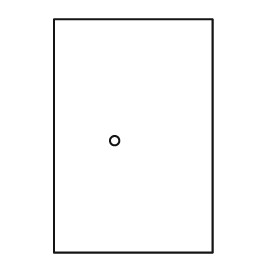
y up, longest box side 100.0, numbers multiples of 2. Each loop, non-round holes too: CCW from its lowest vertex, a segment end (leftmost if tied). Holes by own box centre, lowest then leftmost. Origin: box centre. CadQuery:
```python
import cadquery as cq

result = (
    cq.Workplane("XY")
    .moveTo(-34.0, -50.0)
    .lineTo(34.0, -50.0)
    .lineTo(34.0, 50.0)
    .lineTo(-34.0, 50.0)
    .close()
    .moveTo(-8.0, -2.0)
    .circle(2.0)
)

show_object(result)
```